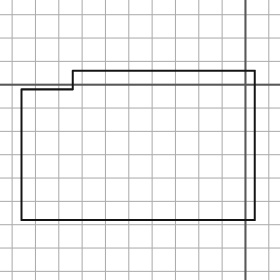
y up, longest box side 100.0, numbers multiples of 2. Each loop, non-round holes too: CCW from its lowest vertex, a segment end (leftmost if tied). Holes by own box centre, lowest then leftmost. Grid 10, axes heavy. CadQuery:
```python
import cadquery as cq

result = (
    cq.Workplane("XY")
    .moveTo(-96.0, -58.0)
    .lineTo(4.0, -58.0)
    .lineTo(4.0, 6.0)
    .lineTo(-74.0, 6.0)
    .lineTo(-74.0, -2.0)
    .lineTo(-96.0, -2.0)
    .close()
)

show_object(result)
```